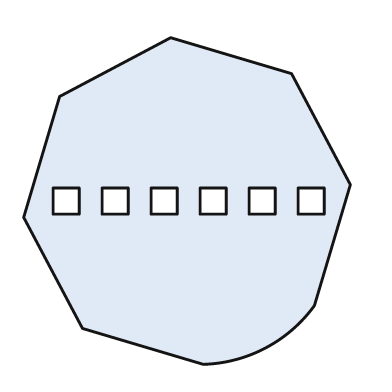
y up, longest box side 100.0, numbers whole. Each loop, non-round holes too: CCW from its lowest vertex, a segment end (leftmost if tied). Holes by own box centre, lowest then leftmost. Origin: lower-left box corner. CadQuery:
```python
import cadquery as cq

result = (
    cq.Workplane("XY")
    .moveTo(55.0, 0.0)
    .threePointArc((74.0, 5.0), (89.0, 18.0))
    .lineTo(100.0, 55.0)
    .lineTo(82.0, 89.0)
    .lineTo(45.0, 100.0)
    .lineTo(11.0, 82.0)
    .lineTo(0.0, 45.0)
    .lineTo(18.0, 11.0)
    .close()
    .moveTo(9.0, 46.0)
    .lineTo(17.0, 46.0)
    .lineTo(17.0, 54.0)
    .lineTo(9.0, 54.0)
    .close()
    .moveTo(24.0, 46.0)
    .lineTo(32.0, 46.0)
    .lineTo(32.0, 54.0)
    .lineTo(24.0, 54.0)
    .close()
    .moveTo(39.0, 46.0)
    .lineTo(47.0, 46.0)
    .lineTo(47.0, 54.0)
    .lineTo(39.0, 54.0)
    .close()
    .moveTo(54.0, 46.0)
    .lineTo(62.0, 46.0)
    .lineTo(62.0, 54.0)
    .lineTo(54.0, 54.0)
    .close()
    .moveTo(69.0, 46.0)
    .lineTo(77.0, 46.0)
    .lineTo(77.0, 54.0)
    .lineTo(69.0, 54.0)
    .close()
    .moveTo(84.0, 46.0)
    .lineTo(92.0, 46.0)
    .lineTo(92.0, 54.0)
    .lineTo(84.0, 54.0)
    .close()
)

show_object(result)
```